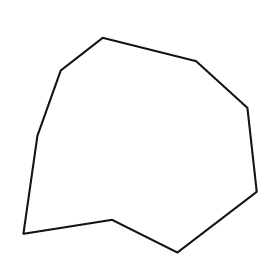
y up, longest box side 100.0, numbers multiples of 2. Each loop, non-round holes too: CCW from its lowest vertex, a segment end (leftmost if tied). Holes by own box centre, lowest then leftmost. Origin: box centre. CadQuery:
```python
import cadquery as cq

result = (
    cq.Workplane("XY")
    .moveTo(16.0, -46.0)
    .lineTo(50.0, -20.0)
    .lineTo(46.0, 16.0)
    .lineTo(24.0, 36.0)
    .lineTo(-16.0, 46.0)
    .lineTo(-34.0, 32.0)
    .lineTo(-44.0, 4.0)
    .lineTo(-50.0, -38.0)
    .lineTo(-12.0, -32.0)
    .close()
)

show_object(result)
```